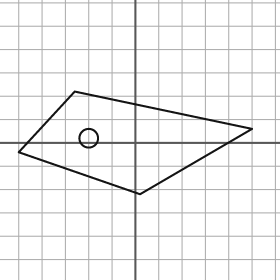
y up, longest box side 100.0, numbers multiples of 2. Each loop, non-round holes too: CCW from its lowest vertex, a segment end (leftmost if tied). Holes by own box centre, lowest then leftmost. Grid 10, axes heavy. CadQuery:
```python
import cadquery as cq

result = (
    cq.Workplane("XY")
    .moveTo(2.0, -22.0)
    .lineTo(50.0, 6.0)
    .lineTo(-26.0, 22.0)
    .lineTo(-50.0, -4.0)
    .close()
    .moveTo(-20.0, 2.0)
    .circle(4.0)
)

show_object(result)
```